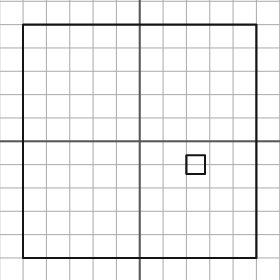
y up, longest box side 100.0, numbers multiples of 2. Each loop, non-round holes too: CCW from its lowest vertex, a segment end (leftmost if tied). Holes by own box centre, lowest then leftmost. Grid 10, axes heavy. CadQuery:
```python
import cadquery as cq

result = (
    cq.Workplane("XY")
    .moveTo(-50.0, -50.0)
    .lineTo(50.0, -50.0)
    .lineTo(50.0, 50.0)
    .lineTo(-50.0, 50.0)
    .close()
    .moveTo(20.0, -14.0)
    .lineTo(28.0, -14.0)
    .lineTo(28.0, -6.0)
    .lineTo(20.0, -6.0)
    .close()
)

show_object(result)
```